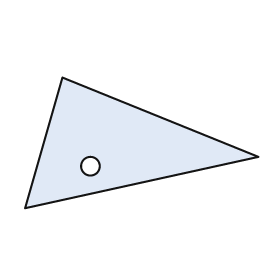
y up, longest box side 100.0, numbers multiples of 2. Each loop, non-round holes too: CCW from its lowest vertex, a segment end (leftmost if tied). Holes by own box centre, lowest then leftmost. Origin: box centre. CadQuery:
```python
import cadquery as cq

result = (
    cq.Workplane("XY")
    .moveTo(-50.0, -28.0)
    .lineTo(50.0, -6.0)
    .lineTo(-34.0, 28.0)
    .close()
    .moveTo(-22.0, -10.0)
    .circle(4.0)
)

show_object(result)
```